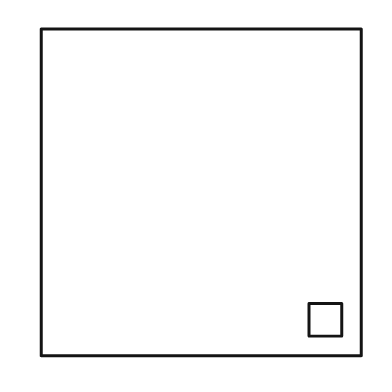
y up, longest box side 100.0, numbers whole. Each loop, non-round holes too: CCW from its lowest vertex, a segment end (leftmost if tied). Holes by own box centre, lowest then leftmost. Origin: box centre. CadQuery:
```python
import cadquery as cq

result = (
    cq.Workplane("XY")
    .moveTo(-49.0, -50.0)
    .lineTo(49.0, -50.0)
    .lineTo(49.0, 50.0)
    .lineTo(-49.0, 50.0)
    .close()
    .moveTo(33.0, -44.0)
    .lineTo(43.0, -44.0)
    .lineTo(43.0, -34.0)
    .lineTo(33.0, -34.0)
    .close()
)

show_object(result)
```